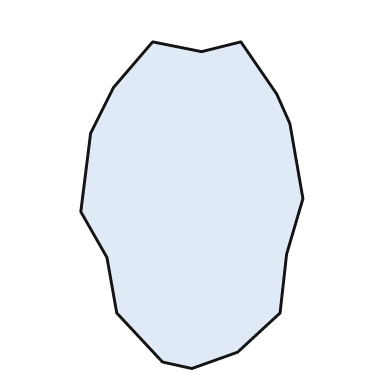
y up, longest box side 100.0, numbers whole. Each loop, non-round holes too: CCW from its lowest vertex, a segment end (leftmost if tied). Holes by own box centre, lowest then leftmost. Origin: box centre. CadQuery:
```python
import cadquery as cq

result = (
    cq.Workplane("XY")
    .moveTo(0.0, -50.0)
    .lineTo(14.0, -45.0)
    .lineTo(27.0, -33.0)
    .lineTo(29.0, -15.0)
    .lineTo(34.0, 2.0)
    .lineTo(30.0, 25.0)
    .lineTo(26.0, 34.0)
    .lineTo(15.0, 50.0)
    .lineTo(3.0, 47.0)
    .lineTo(-12.0, 50.0)
    .lineTo(-24.0, 36.0)
    .lineTo(-31.0, 22.0)
    .lineTo(-34.0, -2.0)
    .lineTo(-26.0, -16.0)
    .lineTo(-23.0, -33.0)
    .lineTo(-9.0, -48.0)
    .close()
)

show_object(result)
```